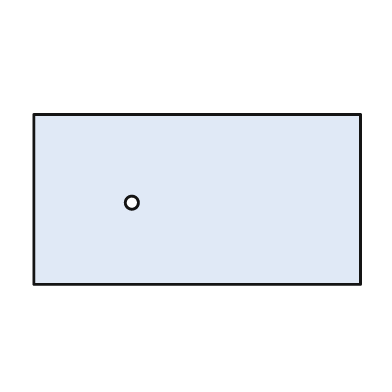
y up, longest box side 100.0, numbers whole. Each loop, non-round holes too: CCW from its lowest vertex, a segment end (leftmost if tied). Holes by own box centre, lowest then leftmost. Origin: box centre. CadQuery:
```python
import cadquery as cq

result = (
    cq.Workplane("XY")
    .moveTo(-50.0, -26.0)
    .lineTo(50.0, -26.0)
    .lineTo(50.0, 26.0)
    .lineTo(-50.0, 26.0)
    .close()
    .moveTo(-20.0, -1.0)
    .circle(2.0)
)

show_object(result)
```